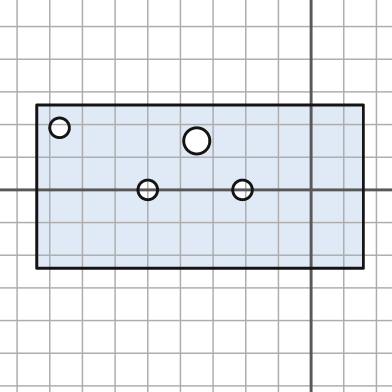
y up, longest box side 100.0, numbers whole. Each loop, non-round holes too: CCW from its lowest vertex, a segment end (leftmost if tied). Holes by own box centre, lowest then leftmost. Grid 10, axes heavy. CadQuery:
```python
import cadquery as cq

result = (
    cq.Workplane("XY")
    .moveTo(-84.0, -24.0)
    .lineTo(16.0, -24.0)
    .lineTo(16.0, 26.0)
    .lineTo(-84.0, 26.0)
    .close()
    .moveTo(-50.0, 0.0)
    .circle(3.0)
    .moveTo(-21.0, 0.0)
    .circle(3.0)
    .moveTo(-35.0, 15.0)
    .circle(4.0)
    .moveTo(-77.0, 19.0)
    .circle(3.0)
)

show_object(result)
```